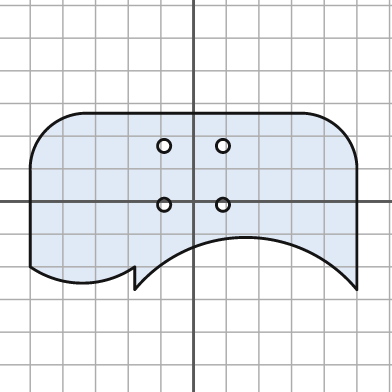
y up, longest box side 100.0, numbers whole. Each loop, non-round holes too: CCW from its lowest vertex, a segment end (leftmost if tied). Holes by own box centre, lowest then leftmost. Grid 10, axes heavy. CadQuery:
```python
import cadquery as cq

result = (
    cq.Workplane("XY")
    .moveTo(-18.0, -27.0)
    .threePointArc((16.0, -11.0), (50.0, -27.0))
    .lineTo(50.0, 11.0)
    .threePointArc((45.0, 22.0), (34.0, 27.0))
    .lineTo(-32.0, 27.0)
    .threePointArc((-45.0, 22.0), (-50.0, 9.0))
    .lineTo(-50.0, -20.0)
    .threePointArc((-34.0, -25.0), (-18.0, -20.0))
    .close()
    .moveTo(-9.0, -1.0)
    .circle(2.0)
    .moveTo(9.0, -1.0)
    .circle(2.0)
    .moveTo(-9.0, 17.0)
    .circle(2.0)
    .moveTo(9.0, 17.0)
    .circle(2.0)
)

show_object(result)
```